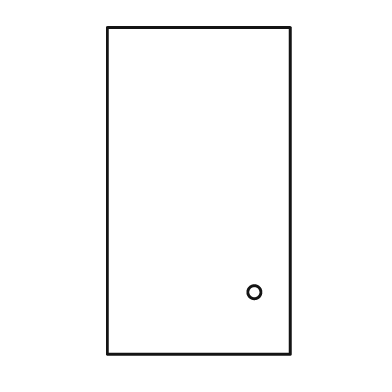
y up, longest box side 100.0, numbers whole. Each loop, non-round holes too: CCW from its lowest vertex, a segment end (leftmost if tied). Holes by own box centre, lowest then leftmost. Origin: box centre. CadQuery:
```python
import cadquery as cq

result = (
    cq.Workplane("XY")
    .moveTo(-28.0, -50.0)
    .lineTo(28.0, -50.0)
    .lineTo(28.0, 50.0)
    .lineTo(-28.0, 50.0)
    .close()
    .moveTo(17.0, -31.0)
    .circle(2.0)
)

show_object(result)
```